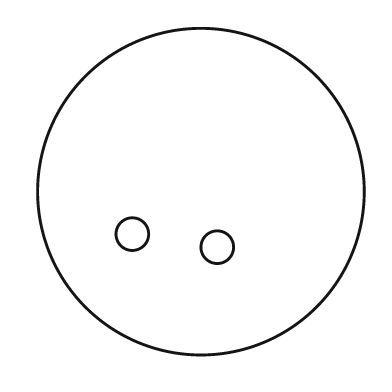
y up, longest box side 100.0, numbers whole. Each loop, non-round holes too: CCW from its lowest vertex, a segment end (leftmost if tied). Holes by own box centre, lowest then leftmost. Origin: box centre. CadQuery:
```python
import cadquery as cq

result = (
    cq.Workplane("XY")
    .moveTo(0.0, 0.0)
    .circle(50.0)
    .moveTo(5.0, -17.0)
    .circle(5.0)
    .moveTo(-21.0, -13.0)
    .circle(5.0)
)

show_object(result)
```